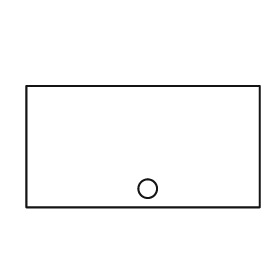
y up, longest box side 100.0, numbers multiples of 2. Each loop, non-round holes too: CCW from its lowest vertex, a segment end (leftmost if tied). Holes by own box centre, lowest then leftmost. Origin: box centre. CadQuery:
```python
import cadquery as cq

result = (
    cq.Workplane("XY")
    .moveTo(-50.0, -26.0)
    .lineTo(50.0, -26.0)
    .lineTo(50.0, 26.0)
    .lineTo(-50.0, 26.0)
    .close()
    .moveTo(2.0, -18.0)
    .circle(4.0)
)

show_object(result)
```